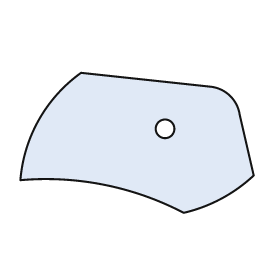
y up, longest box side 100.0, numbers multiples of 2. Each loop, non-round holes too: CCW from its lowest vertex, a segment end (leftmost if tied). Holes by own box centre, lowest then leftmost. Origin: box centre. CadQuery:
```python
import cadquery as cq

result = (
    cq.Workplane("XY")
    .moveTo(20.0, -30.0)
    .threePointArc((36.0, -24.0), (50.0, -14.0))
    .lineTo(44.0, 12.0)
    .threePointArc((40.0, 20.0), (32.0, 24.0))
    .lineTo(-24.0, 30.0)
    .threePointArc((-42.0, 10.0), (-50.0, -16.0))
    .threePointArc((-14.0, -18.0), (20.0, -30.0))
    .close()
    .moveTo(12.0, 6.0)
    .circle(4.0)
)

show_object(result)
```